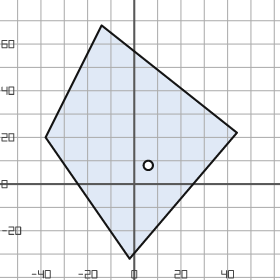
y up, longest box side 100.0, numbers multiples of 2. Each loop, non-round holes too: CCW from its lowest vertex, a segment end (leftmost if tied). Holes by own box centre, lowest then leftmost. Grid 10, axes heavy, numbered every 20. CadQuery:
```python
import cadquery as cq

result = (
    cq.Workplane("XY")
    .moveTo(-2.0, -32.0)
    .lineTo(44.0, 22.0)
    .lineTo(-14.0, 68.0)
    .lineTo(-38.0, 20.0)
    .close()
    .moveTo(6.0, 8.0)
    .circle(2.0)
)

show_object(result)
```